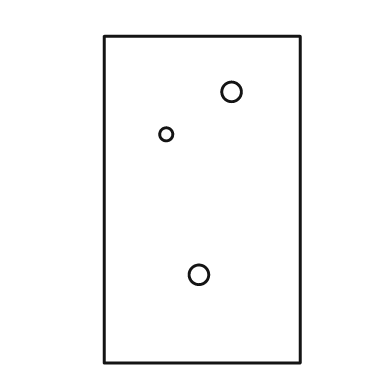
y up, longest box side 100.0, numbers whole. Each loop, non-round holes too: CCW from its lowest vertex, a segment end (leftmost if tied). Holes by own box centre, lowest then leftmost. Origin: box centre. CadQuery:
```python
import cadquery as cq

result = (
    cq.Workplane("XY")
    .moveTo(-30.0, -50.0)
    .lineTo(30.0, -50.0)
    .lineTo(30.0, 50.0)
    .lineTo(-30.0, 50.0)
    .close()
    .moveTo(-1.0, -23.0)
    .circle(3.0)
    .moveTo(-11.0, 20.0)
    .circle(2.0)
    .moveTo(9.0, 33.0)
    .circle(3.0)
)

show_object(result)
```